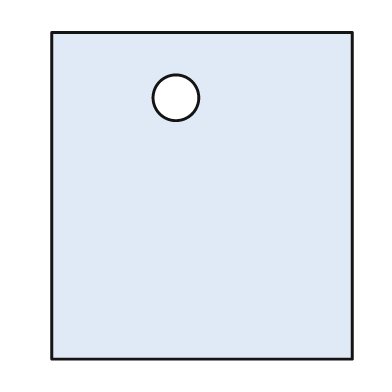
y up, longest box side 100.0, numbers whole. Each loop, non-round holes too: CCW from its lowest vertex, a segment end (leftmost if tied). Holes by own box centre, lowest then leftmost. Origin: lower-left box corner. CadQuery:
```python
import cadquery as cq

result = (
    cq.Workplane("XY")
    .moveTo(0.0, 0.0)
    .lineTo(92.0, 0.0)
    .lineTo(92.0, 100.0)
    .lineTo(0.0, 100.0)
    .close()
    .moveTo(38.0, 80.0)
    .circle(7.0)
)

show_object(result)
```